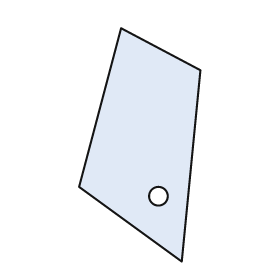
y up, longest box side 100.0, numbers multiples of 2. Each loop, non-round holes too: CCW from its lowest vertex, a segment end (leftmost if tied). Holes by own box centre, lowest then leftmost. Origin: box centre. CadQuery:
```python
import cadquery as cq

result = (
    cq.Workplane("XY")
    .moveTo(18.0, -50.0)
    .lineTo(26.0, 32.0)
    .lineTo(-8.0, 50.0)
    .lineTo(-26.0, -18.0)
    .close()
    .moveTo(8.0, -22.0)
    .circle(4.0)
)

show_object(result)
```